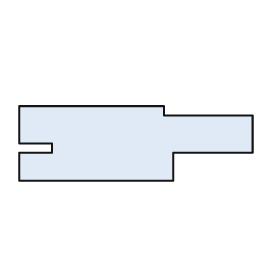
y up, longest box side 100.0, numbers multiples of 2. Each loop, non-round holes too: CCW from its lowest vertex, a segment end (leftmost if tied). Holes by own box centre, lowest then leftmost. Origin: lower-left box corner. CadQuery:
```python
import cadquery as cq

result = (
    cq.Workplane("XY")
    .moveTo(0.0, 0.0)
    .lineTo(66.0, 0.0)
    .lineTo(66.0, 12.0)
    .lineTo(100.0, 12.0)
    .lineTo(100.0, 28.0)
    .lineTo(62.0, 28.0)
    .lineTo(62.0, 32.0)
    .lineTo(0.0, 32.0)
    .lineTo(0.0, 16.0)
    .lineTo(14.0, 16.0)
    .lineTo(14.0, 12.0)
    .lineTo(0.0, 12.0)
    .close()
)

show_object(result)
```